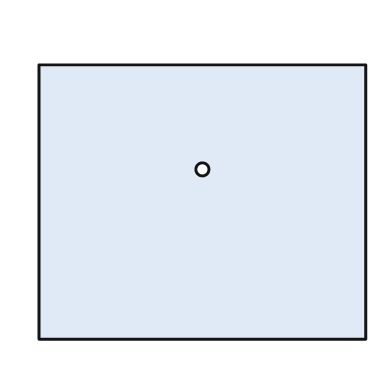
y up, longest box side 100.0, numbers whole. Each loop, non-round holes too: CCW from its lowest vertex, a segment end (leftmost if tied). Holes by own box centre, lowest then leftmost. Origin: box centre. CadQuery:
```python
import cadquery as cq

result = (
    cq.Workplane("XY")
    .moveTo(-50.0, -42.0)
    .lineTo(50.0, -42.0)
    .lineTo(50.0, 42.0)
    .lineTo(-50.0, 42.0)
    .close()
    .moveTo(0.0, 10.0)
    .circle(2.0)
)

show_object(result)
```